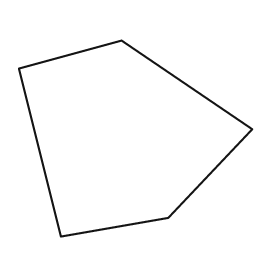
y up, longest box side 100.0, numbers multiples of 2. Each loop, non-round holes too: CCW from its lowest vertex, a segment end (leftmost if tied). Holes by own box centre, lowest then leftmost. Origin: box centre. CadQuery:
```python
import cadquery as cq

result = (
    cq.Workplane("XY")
    .moveTo(-32.0, -42.0)
    .lineTo(14.0, -34.0)
    .lineTo(50.0, 4.0)
    .lineTo(-6.0, 42.0)
    .lineTo(-50.0, 30.0)
    .close()
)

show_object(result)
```